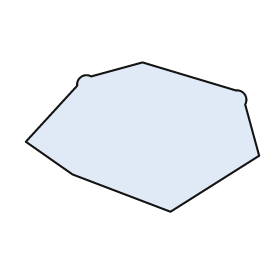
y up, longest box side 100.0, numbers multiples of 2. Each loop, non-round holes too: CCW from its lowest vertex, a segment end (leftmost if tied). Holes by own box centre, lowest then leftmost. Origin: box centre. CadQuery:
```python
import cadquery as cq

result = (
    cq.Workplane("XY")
    .moveTo(12.0, -32.0)
    .lineTo(50.0, -8.0)
    .lineTo(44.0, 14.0)
    .threePointArc((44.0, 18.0), (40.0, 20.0))
    .lineTo(0.0, 32.0)
    .lineTo(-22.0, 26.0)
    .threePointArc((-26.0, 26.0), (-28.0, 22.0))
    .lineTo(-50.0, -2.0)
    .lineTo(-30.0, -16.0)
    .close()
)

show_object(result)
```